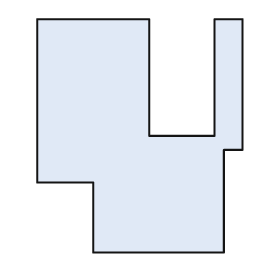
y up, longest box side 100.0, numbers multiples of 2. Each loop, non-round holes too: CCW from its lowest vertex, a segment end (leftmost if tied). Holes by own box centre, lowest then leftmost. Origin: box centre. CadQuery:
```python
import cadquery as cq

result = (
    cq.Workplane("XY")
    .moveTo(-20.0, -50.0)
    .lineTo(36.0, -50.0)
    .lineTo(36.0, -6.0)
    .lineTo(44.0, -6.0)
    .lineTo(44.0, 50.0)
    .lineTo(32.0, 50.0)
    .lineTo(32.0, 0.0)
    .lineTo(4.0, 0.0)
    .lineTo(4.0, 50.0)
    .lineTo(-44.0, 50.0)
    .lineTo(-44.0, -20.0)
    .lineTo(-20.0, -20.0)
    .close()
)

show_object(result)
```